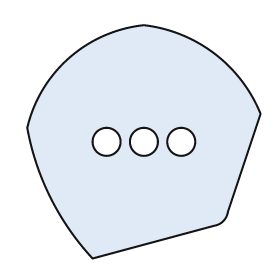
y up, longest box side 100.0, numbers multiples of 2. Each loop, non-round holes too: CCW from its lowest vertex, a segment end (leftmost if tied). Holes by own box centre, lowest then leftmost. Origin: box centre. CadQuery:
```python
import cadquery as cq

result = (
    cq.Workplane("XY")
    .moveTo(-22.0, -50.0)
    .lineTo(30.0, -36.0)
    .threePointArc((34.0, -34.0), (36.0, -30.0))
    .lineTo(50.0, 12.0)
    .threePointArc((30.0, 38.0), (0.0, 50.0))
    .threePointArc((-32.0, 36.0), (-50.0, 6.0))
    .threePointArc((-40.0, -24.0), (-22.0, -50.0))
    .close()
    .moveTo(-16.0, 0.0)
    .circle(6.0)
    .moveTo(0.0, 0.0)
    .circle(6.0)
    .moveTo(16.0, 0.0)
    .circle(6.0)
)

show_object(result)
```